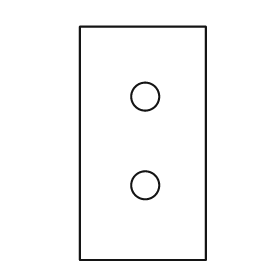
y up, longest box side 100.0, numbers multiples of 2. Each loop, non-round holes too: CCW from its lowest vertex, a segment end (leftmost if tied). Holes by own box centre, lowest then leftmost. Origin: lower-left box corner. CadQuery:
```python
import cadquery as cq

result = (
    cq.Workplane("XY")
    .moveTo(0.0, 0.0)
    .lineTo(54.0, 0.0)
    .lineTo(54.0, 100.0)
    .lineTo(0.0, 100.0)
    .close()
    .moveTo(28.0, 32.0)
    .circle(6.0)
    .moveTo(28.0, 70.0)
    .circle(6.0)
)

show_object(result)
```